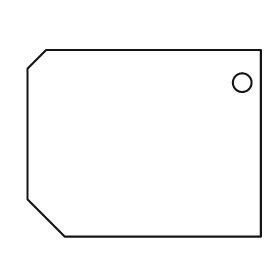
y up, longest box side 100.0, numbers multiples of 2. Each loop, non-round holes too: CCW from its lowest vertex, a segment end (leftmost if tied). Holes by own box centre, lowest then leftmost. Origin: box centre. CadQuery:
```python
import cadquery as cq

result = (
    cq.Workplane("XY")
    .moveTo(-34.0, -40.0)
    .lineTo(50.0, -40.0)
    .lineTo(50.0, 40.0)
    .lineTo(-42.0, 40.0)
    .lineTo(-50.0, 32.0)
    .lineTo(-50.0, -24.0)
    .close()
    .moveTo(42.0, 26.0)
    .circle(4.0)
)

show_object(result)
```